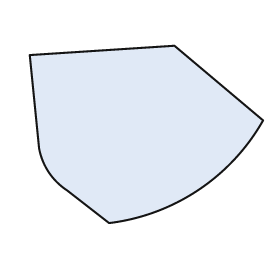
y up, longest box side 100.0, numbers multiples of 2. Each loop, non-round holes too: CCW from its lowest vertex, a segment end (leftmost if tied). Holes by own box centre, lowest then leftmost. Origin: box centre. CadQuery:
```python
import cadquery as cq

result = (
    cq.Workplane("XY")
    .moveTo(-16.0, -38.0)
    .threePointArc((22.0, -24.0), (50.0, 6.0))
    .lineTo(12.0, 38.0)
    .lineTo(-50.0, 34.0)
    .lineTo(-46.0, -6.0)
    .threePointArc((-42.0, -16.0), (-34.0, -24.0))
    .close()
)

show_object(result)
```